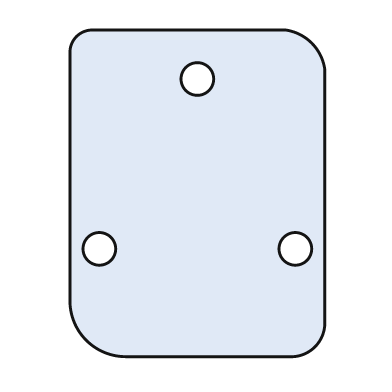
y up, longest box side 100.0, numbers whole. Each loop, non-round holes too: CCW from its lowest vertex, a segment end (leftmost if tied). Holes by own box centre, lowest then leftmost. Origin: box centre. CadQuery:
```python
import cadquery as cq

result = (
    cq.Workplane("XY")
    .moveTo(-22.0, -50.0)
    .lineTo(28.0, -50.0)
    .threePointArc((36.0, -47.0), (39.0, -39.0))
    .lineTo(39.0, 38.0)
    .threePointArc((35.0, 46.0), (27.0, 50.0))
    .lineTo(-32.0, 50.0)
    .threePointArc((-37.0, 48.0), (-39.0, 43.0))
    .lineTo(-39.0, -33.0)
    .threePointArc((-34.0, -45.0), (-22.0, -50.0))
    .close()
    .moveTo(-30.0, -17.0)
    .circle(5.0)
    .moveTo(30.0, -17.0)
    .circle(5.0)
    .moveTo(0.0, 35.0)
    .circle(5.0)
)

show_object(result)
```